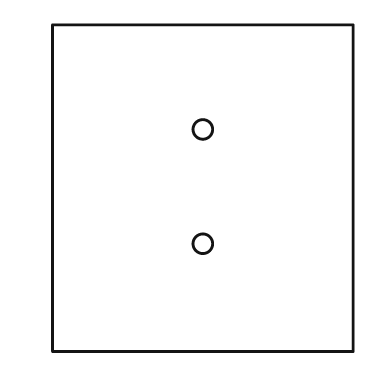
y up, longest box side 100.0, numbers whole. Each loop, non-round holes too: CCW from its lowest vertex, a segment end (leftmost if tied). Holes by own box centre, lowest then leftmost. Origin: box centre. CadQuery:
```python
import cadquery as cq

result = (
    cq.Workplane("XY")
    .moveTo(-46.0, -50.0)
    .lineTo(46.0, -50.0)
    .lineTo(46.0, 50.0)
    .lineTo(-46.0, 50.0)
    .close()
    .moveTo(0.0, -17.0)
    .circle(3.0)
    .moveTo(0.0, 18.0)
    .circle(3.0)
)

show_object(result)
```